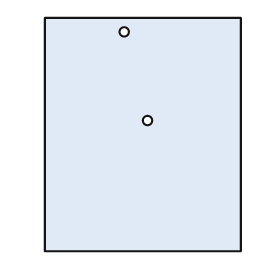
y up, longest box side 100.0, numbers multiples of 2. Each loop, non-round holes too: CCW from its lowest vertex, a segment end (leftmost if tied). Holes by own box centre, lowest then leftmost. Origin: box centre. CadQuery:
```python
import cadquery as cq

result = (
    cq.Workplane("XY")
    .moveTo(-42.0, -50.0)
    .lineTo(42.0, -50.0)
    .lineTo(42.0, 50.0)
    .lineTo(-42.0, 50.0)
    .close()
    .moveTo(2.0, 6.0)
    .circle(2.0)
    .moveTo(-8.0, 44.0)
    .circle(2.0)
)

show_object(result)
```